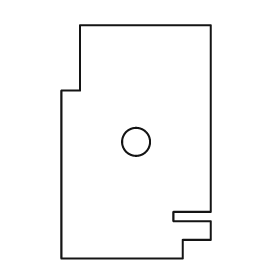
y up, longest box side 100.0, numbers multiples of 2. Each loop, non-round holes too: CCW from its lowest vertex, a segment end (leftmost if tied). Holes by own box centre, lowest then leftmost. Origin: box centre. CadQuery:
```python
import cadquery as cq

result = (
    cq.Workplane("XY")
    .moveTo(-32.0, -50.0)
    .lineTo(20.0, -50.0)
    .lineTo(20.0, -42.0)
    .lineTo(32.0, -42.0)
    .lineTo(32.0, -34.0)
    .lineTo(16.0, -34.0)
    .lineTo(16.0, -30.0)
    .lineTo(32.0, -30.0)
    .lineTo(32.0, 50.0)
    .lineTo(-24.0, 50.0)
    .lineTo(-24.0, 22.0)
    .lineTo(-32.0, 22.0)
    .close()
    .moveTo(0.0, 0.0)
    .circle(6.0)
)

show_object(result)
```